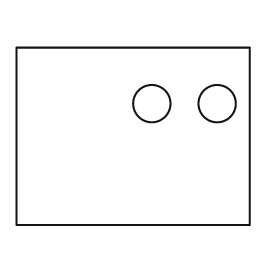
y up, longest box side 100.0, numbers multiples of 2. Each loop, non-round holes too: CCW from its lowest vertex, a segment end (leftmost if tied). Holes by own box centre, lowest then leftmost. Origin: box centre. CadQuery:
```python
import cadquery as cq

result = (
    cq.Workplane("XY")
    .moveTo(-50.0, -38.0)
    .lineTo(50.0, -38.0)
    .lineTo(50.0, 38.0)
    .lineTo(-50.0, 38.0)
    .close()
    .moveTo(8.0, 14.0)
    .circle(8.0)
    .moveTo(36.0, 14.0)
    .circle(8.0)
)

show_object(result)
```